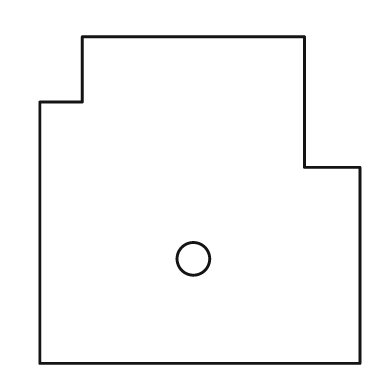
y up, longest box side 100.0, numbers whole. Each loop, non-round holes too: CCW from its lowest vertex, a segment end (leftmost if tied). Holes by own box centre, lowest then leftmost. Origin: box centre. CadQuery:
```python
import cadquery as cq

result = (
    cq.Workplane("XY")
    .moveTo(-49.0, -50.0)
    .lineTo(49.0, -50.0)
    .lineTo(49.0, 10.0)
    .lineTo(32.0, 10.0)
    .lineTo(32.0, 50.0)
    .lineTo(-36.0, 50.0)
    .lineTo(-36.0, 30.0)
    .lineTo(-49.0, 30.0)
    .close()
    .moveTo(-2.0, -18.0)
    .circle(5.0)
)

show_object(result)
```